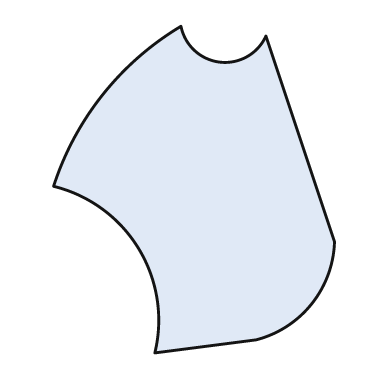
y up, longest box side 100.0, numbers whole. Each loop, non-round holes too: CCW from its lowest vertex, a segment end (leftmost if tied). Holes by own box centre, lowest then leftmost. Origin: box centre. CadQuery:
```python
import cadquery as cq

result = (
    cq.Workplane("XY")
    .moveTo(-12.0, -50.0)
    .lineTo(19.0, -46.0)
    .threePointArc((36.0, -35.0), (43.0, -16.0))
    .lineTo(22.0, 47.0)
    .threePointArc((8.0, 39.0), (-4.0, 50.0))
    .threePointArc((-28.0, 29.0), (-43.0, 1.0))
    .threePointArc((-17.0, -18.0), (-12.0, -50.0))
    .close()
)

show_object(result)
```